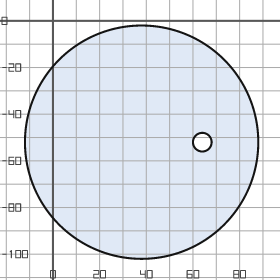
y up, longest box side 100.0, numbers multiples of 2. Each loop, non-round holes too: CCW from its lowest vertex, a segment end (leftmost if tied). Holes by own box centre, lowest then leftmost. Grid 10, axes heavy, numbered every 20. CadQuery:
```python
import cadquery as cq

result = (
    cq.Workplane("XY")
    .moveTo(38.0, -52.0)
    .circle(50.0)
    .moveTo(64.0, -52.0)
    .circle(4.0)
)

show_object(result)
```